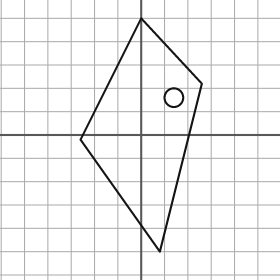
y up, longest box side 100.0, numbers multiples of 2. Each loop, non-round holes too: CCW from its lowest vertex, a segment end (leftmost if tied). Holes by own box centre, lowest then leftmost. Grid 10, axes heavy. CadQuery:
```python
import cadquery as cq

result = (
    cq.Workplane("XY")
    .moveTo(8.0, -50.0)
    .lineTo(26.0, 22.0)
    .lineTo(0.0, 50.0)
    .lineTo(-26.0, -2.0)
    .close()
    .moveTo(14.0, 16.0)
    .circle(4.0)
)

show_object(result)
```